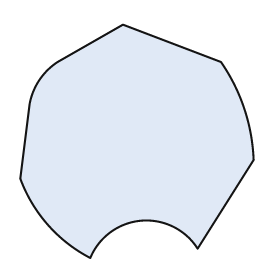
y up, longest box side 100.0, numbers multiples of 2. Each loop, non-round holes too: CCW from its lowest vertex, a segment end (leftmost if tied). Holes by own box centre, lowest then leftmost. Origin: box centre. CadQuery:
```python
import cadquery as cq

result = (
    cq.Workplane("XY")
    .moveTo(-20.0, -50.0)
    .threePointArc((2.0, -34.0), (26.0, -46.0))
    .lineTo(50.0, -8.0)
    .threePointArc((46.0, 14.0), (36.0, 34.0))
    .lineTo(-6.0, 50.0)
    .lineTo(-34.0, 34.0)
    .threePointArc((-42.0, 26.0), (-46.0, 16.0))
    .lineTo(-50.0, -16.0)
    .threePointArc((-38.0, -36.0), (-20.0, -50.0))
    .close()
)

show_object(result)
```